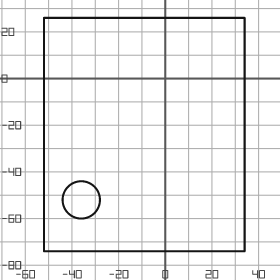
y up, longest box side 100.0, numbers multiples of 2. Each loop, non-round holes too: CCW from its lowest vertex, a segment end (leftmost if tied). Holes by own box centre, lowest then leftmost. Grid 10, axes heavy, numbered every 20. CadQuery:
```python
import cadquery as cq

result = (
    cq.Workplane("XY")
    .moveTo(-52.0, -74.0)
    .lineTo(34.0, -74.0)
    .lineTo(34.0, 26.0)
    .lineTo(-52.0, 26.0)
    .close()
    .moveTo(-36.0, -52.0)
    .circle(8.0)
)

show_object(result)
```